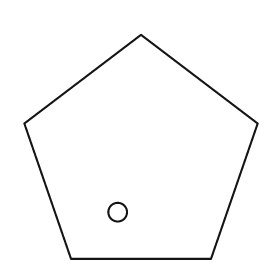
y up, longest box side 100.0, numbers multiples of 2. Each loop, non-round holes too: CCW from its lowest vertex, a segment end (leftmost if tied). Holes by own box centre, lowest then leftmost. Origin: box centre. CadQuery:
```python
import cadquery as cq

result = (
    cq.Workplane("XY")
    .moveTo(-30.0, -48.0)
    .lineTo(30.0, -48.0)
    .lineTo(50.0, 10.0)
    .lineTo(0.0, 48.0)
    .lineTo(-50.0, 10.0)
    .close()
    .moveTo(-10.0, -28.0)
    .circle(4.0)
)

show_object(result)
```